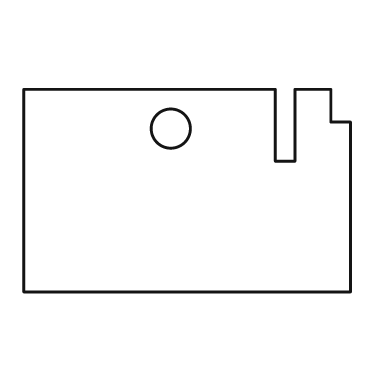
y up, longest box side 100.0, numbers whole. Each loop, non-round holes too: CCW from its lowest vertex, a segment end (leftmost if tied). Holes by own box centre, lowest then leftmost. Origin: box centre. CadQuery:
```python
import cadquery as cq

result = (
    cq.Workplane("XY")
    .moveTo(-50.0, -31.0)
    .lineTo(50.0, -31.0)
    .lineTo(50.0, 21.0)
    .lineTo(44.0, 21.0)
    .lineTo(44.0, 31.0)
    .lineTo(33.0, 31.0)
    .lineTo(33.0, 9.0)
    .lineTo(27.0, 9.0)
    .lineTo(27.0, 31.0)
    .lineTo(-50.0, 31.0)
    .close()
    .moveTo(-5.0, 19.0)
    .circle(6.0)
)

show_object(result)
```